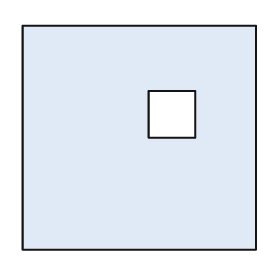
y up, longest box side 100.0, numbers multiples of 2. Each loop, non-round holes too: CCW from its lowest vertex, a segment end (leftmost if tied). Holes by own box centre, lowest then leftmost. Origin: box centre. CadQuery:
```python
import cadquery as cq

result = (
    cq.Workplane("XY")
    .moveTo(-50.0, -48.0)
    .lineTo(50.0, -48.0)
    .lineTo(50.0, 48.0)
    .lineTo(-50.0, 48.0)
    .close()
    .moveTo(4.0, 0.0)
    .lineTo(24.0, 0.0)
    .lineTo(24.0, 20.0)
    .lineTo(4.0, 20.0)
    .close()
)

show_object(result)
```